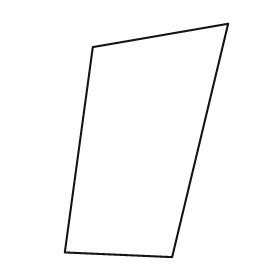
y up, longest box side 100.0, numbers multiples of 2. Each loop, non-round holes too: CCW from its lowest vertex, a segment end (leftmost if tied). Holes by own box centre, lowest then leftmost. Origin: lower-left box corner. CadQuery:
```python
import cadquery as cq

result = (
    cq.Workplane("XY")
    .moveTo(46.0, 0.0)
    .lineTo(70.0, 100.0)
    .lineTo(12.0, 90.0)
    .lineTo(0.0, 2.0)
    .close()
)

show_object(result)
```